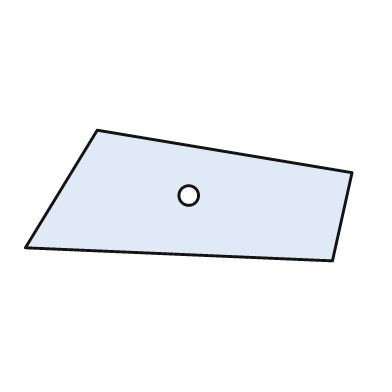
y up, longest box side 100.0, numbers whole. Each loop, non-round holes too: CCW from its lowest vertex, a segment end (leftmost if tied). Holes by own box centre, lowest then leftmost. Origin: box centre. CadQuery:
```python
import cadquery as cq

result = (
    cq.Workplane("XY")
    .moveTo(44.0, -20.0)
    .lineTo(50.0, 7.0)
    .lineTo(-28.0, 20.0)
    .lineTo(-50.0, -16.0)
    .close()
    .moveTo(0.0, 0.0)
    .circle(3.0)
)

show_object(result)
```